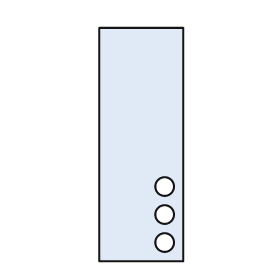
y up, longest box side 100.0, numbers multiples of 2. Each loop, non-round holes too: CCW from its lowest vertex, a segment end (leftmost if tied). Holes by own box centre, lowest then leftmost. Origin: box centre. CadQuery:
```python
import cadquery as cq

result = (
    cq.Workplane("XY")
    .moveTo(-18.0, -50.0)
    .lineTo(18.0, -50.0)
    .lineTo(18.0, 50.0)
    .lineTo(-18.0, 50.0)
    .close()
    .moveTo(10.0, -42.0)
    .circle(4.0)
    .moveTo(10.0, -30.0)
    .circle(4.0)
    .moveTo(10.0, -18.0)
    .circle(4.0)
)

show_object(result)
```